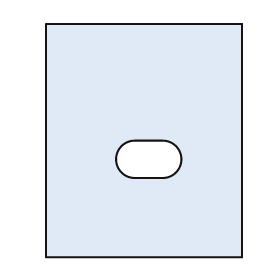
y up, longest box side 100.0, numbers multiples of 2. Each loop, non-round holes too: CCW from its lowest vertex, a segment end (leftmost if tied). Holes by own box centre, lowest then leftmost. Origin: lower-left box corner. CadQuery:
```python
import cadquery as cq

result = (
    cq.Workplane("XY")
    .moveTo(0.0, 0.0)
    .lineTo(84.0, 0.0)
    .lineTo(84.0, 100.0)
    .lineTo(0.0, 100.0)
    .close()
    .moveTo(38.0, 34.0)
    .lineTo(50.0, 34.0)
    .threePointArc((58.0, 42.0), (50.0, 50.0))
    .lineTo(38.0, 50.0)
    .threePointArc((30.0, 42.0), (38.0, 34.0))
    .close()
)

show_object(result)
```